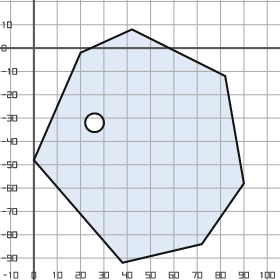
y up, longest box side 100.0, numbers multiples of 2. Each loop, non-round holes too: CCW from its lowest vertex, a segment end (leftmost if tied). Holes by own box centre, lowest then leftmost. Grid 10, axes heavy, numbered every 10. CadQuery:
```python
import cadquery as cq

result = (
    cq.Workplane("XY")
    .moveTo(38.0, -92.0)
    .lineTo(72.0, -84.0)
    .lineTo(90.0, -58.0)
    .lineTo(82.0, -12.0)
    .lineTo(42.0, 8.0)
    .lineTo(20.0, -2.0)
    .lineTo(0.0, -48.0)
    .close()
    .moveTo(26.0, -32.0)
    .circle(4.0)
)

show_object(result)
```